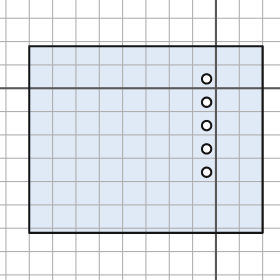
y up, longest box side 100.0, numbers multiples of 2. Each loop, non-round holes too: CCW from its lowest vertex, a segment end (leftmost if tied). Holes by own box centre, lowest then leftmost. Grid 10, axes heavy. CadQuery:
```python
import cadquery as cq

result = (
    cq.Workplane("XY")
    .moveTo(-80.0, -62.0)
    .lineTo(20.0, -62.0)
    .lineTo(20.0, 18.0)
    .lineTo(-80.0, 18.0)
    .close()
    .moveTo(-4.0, -36.0)
    .circle(2.0)
    .moveTo(-4.0, -26.0)
    .circle(2.0)
    .moveTo(-4.0, -16.0)
    .circle(2.0)
    .moveTo(-4.0, -6.0)
    .circle(2.0)
    .moveTo(-4.0, 4.0)
    .circle(2.0)
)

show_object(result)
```